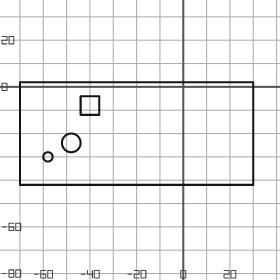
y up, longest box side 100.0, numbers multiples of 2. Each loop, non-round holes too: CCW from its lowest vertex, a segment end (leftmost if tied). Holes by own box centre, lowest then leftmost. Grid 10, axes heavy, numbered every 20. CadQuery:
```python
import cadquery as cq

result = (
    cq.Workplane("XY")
    .moveTo(-70.0, -42.0)
    .lineTo(30.0, -42.0)
    .lineTo(30.0, 2.0)
    .lineTo(-70.0, 2.0)
    .close()
    .moveTo(-58.0, -30.0)
    .circle(2.0)
    .moveTo(-48.0, -24.0)
    .circle(4.0)
    .moveTo(-44.0, -12.0)
    .lineTo(-36.0, -12.0)
    .lineTo(-36.0, -4.0)
    .lineTo(-44.0, -4.0)
    .close()
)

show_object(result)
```